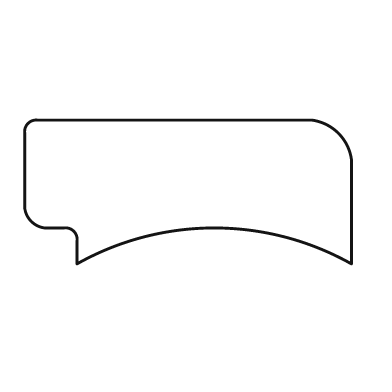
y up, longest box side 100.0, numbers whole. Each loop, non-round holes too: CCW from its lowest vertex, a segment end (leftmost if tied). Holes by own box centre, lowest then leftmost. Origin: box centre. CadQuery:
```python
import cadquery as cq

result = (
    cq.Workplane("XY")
    .moveTo(-34.0, -22.0)
    .threePointArc((8.0, -11.0), (50.0, -22.0))
    .lineTo(50.0, 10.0)
    .threePointArc((46.0, 18.0), (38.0, 22.0))
    .lineTo(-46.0, 22.0)
    .threePointArc((-49.0, 21.0), (-50.0, 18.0))
    .lineTo(-50.0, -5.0)
    .threePointArc((-48.0, -9.0), (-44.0, -11.0))
    .lineTo(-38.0, -11.0)
    .threePointArc((-35.0, -12.0), (-34.0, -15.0))
    .close()
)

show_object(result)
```